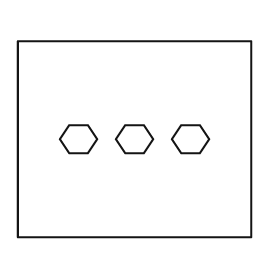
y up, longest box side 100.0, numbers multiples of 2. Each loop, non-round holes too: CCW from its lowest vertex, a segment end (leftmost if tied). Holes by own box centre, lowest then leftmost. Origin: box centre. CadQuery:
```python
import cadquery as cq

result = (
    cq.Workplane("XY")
    .moveTo(-50.0, -42.0)
    .lineTo(50.0, -42.0)
    .lineTo(50.0, 42.0)
    .lineTo(-50.0, 42.0)
    .close()
    .moveTo(-28.0, -6.0)
    .lineTo(-20.0, -6.0)
    .lineTo(-16.0, 0.0)
    .lineTo(-20.0, 6.0)
    .lineTo(-28.0, 6.0)
    .lineTo(-32.0, 0.0)
    .close()
    .moveTo(-4.0, -6.0)
    .lineTo(4.0, -6.0)
    .lineTo(8.0, 0.0)
    .lineTo(4.0, 6.0)
    .lineTo(-4.0, 6.0)
    .lineTo(-8.0, 0.0)
    .close()
    .moveTo(20.0, -6.0)
    .lineTo(28.0, -6.0)
    .lineTo(32.0, 0.0)
    .lineTo(28.0, 6.0)
    .lineTo(20.0, 6.0)
    .lineTo(16.0, 0.0)
    .close()
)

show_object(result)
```